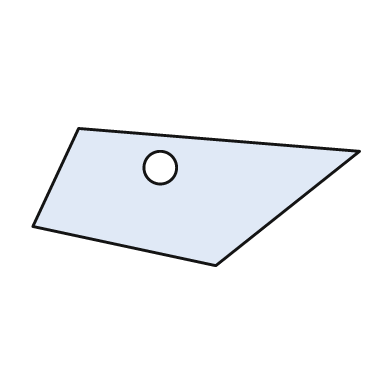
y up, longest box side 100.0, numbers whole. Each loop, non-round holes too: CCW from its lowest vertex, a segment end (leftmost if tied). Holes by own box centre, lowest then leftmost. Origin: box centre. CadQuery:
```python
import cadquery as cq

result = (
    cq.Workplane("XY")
    .moveTo(6.0, -21.0)
    .lineTo(50.0, 14.0)
    .lineTo(-36.0, 21.0)
    .lineTo(-50.0, -9.0)
    .close()
    .moveTo(-11.0, 9.0)
    .circle(5.0)
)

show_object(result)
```